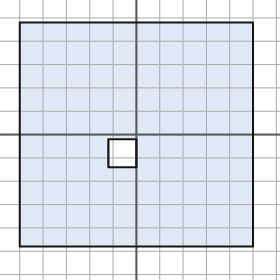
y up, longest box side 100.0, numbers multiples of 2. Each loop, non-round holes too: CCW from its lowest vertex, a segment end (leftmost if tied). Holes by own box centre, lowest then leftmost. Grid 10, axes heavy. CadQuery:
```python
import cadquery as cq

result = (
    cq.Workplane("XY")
    .moveTo(-50.0, -48.0)
    .lineTo(50.0, -48.0)
    .lineTo(50.0, 48.0)
    .lineTo(-50.0, 48.0)
    .close()
    .moveTo(-12.0, -14.0)
    .lineTo(0.0, -14.0)
    .lineTo(0.0, -2.0)
    .lineTo(-12.0, -2.0)
    .close()
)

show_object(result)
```